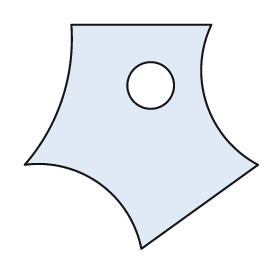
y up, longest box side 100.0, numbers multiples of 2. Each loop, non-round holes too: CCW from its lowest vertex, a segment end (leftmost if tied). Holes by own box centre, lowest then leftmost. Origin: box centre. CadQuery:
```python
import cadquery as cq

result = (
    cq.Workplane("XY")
    .moveTo(0.0, -48.0)
    .lineTo(50.0, -12.0)
    .threePointArc((28.0, 14.0), (30.0, 48.0))
    .lineTo(-30.0, 48.0)
    .threePointArc((-34.0, 16.0), (-50.0, -12.0))
    .threePointArc((-18.0, -20.0), (0.0, -48.0))
    .close()
    .moveTo(4.0, 22.0)
    .circle(10.0)
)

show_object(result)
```